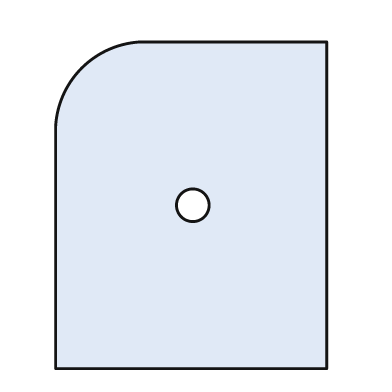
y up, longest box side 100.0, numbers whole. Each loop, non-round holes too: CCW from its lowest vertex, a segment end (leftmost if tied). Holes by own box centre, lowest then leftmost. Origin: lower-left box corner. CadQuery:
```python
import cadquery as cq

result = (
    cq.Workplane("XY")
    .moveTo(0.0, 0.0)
    .lineTo(83.0, 0.0)
    .lineTo(83.0, 100.0)
    .lineTo(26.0, 100.0)
    .threePointArc((8.0, 92.0), (0.0, 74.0))
    .close()
    .moveTo(42.0, 50.0)
    .circle(5.0)
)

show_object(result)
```